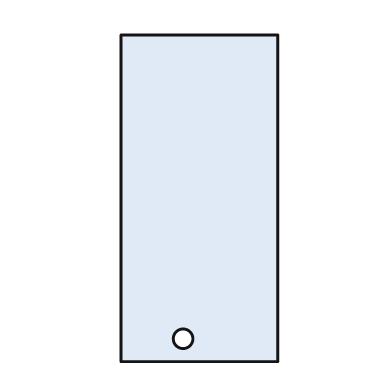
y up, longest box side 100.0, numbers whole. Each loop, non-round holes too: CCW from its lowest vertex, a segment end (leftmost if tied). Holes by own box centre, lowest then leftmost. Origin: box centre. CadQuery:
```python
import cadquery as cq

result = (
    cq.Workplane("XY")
    .moveTo(-24.0, -50.0)
    .lineTo(24.0, -50.0)
    .lineTo(24.0, 50.0)
    .lineTo(-24.0, 50.0)
    .close()
    .moveTo(-5.0, -43.0)
    .circle(3.0)
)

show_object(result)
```